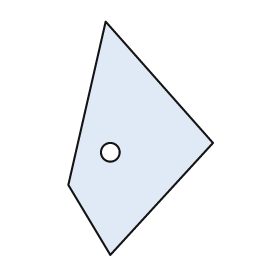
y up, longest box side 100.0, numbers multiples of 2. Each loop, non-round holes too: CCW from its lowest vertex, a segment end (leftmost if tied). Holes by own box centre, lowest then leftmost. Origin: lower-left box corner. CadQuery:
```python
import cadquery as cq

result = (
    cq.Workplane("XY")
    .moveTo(18.0, 0.0)
    .lineTo(62.0, 48.0)
    .lineTo(16.0, 100.0)
    .lineTo(0.0, 30.0)
    .close()
    .moveTo(18.0, 44.0)
    .circle(4.0)
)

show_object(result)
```